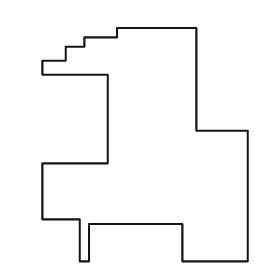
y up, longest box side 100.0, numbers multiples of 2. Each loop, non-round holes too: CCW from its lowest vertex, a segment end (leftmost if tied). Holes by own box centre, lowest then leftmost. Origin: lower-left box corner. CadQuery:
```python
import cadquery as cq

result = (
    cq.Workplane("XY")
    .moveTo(16.0, 0.0)
    .lineTo(20.0, 0.0)
    .lineTo(20.0, 16.0)
    .lineTo(60.0, 16.0)
    .lineTo(60.0, 0.0)
    .lineTo(88.0, 0.0)
    .lineTo(88.0, 56.0)
    .lineTo(66.0, 56.0)
    .lineTo(66.0, 100.0)
    .lineTo(32.0, 100.0)
    .lineTo(32.0, 96.0)
    .lineTo(18.0, 96.0)
    .lineTo(18.0, 92.0)
    .lineTo(10.0, 92.0)
    .lineTo(10.0, 86.0)
    .lineTo(0.0, 86.0)
    .lineTo(0.0, 80.0)
    .lineTo(28.0, 80.0)
    .lineTo(28.0, 42.0)
    .lineTo(0.0, 42.0)
    .lineTo(0.0, 18.0)
    .lineTo(16.0, 18.0)
    .close()
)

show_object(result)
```